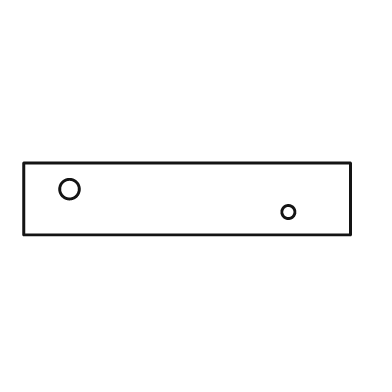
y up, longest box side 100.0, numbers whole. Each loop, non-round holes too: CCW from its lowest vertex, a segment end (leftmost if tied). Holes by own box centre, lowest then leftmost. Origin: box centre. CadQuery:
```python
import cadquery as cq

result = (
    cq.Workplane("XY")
    .moveTo(-50.0, -11.0)
    .lineTo(50.0, -11.0)
    .lineTo(50.0, 11.0)
    .lineTo(-50.0, 11.0)
    .close()
    .moveTo(31.0, -4.0)
    .circle(2.0)
    .moveTo(-36.0, 3.0)
    .circle(3.0)
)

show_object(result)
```